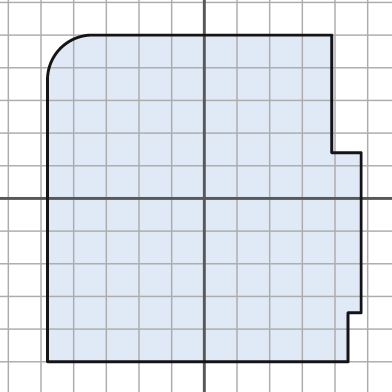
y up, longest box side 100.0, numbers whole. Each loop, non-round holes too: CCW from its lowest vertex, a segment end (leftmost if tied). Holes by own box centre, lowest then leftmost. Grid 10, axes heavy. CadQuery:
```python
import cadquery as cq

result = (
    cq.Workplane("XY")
    .moveTo(-48.0, -50.0)
    .lineTo(44.0, -50.0)
    .lineTo(44.0, -35.0)
    .lineTo(48.0, -35.0)
    .lineTo(48.0, 14.0)
    .lineTo(39.0, 14.0)
    .lineTo(39.0, 50.0)
    .lineTo(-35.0, 50.0)
    .threePointArc((-44.0, 46.0), (-48.0, 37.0))
    .close()
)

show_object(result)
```